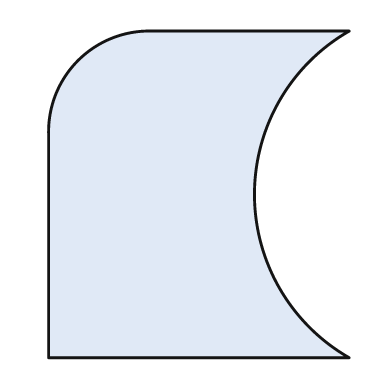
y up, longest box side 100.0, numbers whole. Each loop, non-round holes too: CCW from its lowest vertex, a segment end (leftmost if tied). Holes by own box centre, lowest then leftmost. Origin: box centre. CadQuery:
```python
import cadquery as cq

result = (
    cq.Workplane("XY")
    .moveTo(-46.0, -50.0)
    .lineTo(46.0, -50.0)
    .threePointArc((17.0, 0.0), (46.0, 50.0))
    .lineTo(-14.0, 50.0)
    .threePointArc((-37.0, 41.0), (-46.0, 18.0))
    .close()
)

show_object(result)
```